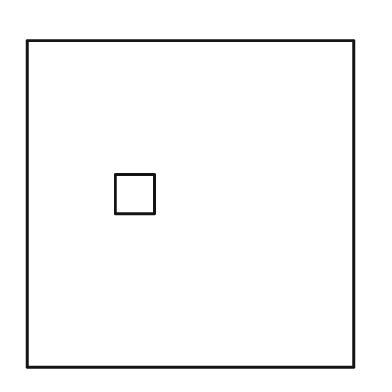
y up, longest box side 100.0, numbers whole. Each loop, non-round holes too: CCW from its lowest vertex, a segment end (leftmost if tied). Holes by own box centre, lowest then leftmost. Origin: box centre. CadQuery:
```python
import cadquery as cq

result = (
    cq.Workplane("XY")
    .moveTo(-50.0, -50.0)
    .lineTo(50.0, -50.0)
    .lineTo(50.0, 50.0)
    .lineTo(-50.0, 50.0)
    .close()
    .moveTo(-23.0, -3.0)
    .lineTo(-11.0, -3.0)
    .lineTo(-11.0, 9.0)
    .lineTo(-23.0, 9.0)
    .close()
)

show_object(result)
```